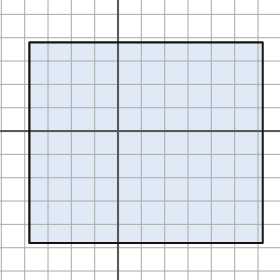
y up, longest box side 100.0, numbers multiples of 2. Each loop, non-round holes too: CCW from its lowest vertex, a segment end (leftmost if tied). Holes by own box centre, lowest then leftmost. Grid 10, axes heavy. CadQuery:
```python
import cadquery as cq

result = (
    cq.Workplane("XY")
    .moveTo(-38.0, -48.0)
    .lineTo(62.0, -48.0)
    .lineTo(62.0, 38.0)
    .lineTo(-38.0, 38.0)
    .close()
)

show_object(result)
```